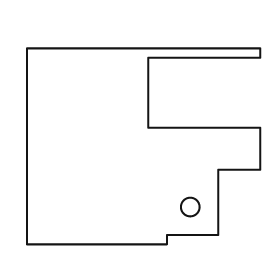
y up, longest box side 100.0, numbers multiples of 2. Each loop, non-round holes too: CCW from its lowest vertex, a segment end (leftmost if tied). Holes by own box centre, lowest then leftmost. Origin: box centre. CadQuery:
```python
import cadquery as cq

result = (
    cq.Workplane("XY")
    .moveTo(-50.0, -42.0)
    .lineTo(10.0, -42.0)
    .lineTo(10.0, -38.0)
    .lineTo(32.0, -38.0)
    .lineTo(32.0, -10.0)
    .lineTo(50.0, -10.0)
    .lineTo(50.0, 8.0)
    .lineTo(2.0, 8.0)
    .lineTo(2.0, 38.0)
    .lineTo(50.0, 38.0)
    .lineTo(50.0, 42.0)
    .lineTo(-50.0, 42.0)
    .close()
    .moveTo(20.0, -26.0)
    .circle(4.0)
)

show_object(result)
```